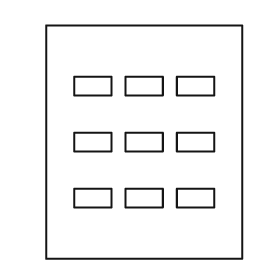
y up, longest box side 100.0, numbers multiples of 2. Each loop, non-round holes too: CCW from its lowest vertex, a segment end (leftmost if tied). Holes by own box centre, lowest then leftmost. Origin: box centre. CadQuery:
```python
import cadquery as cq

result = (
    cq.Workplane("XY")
    .moveTo(-42.0, -50.0)
    .lineTo(42.0, -50.0)
    .lineTo(42.0, 50.0)
    .lineTo(-42.0, 50.0)
    .close()
    .moveTo(-30.0, -28.0)
    .lineTo(-14.0, -28.0)
    .lineTo(-14.0, -20.0)
    .lineTo(-30.0, -20.0)
    .close()
    .moveTo(-8.0, -28.0)
    .lineTo(8.0, -28.0)
    .lineTo(8.0, -20.0)
    .lineTo(-8.0, -20.0)
    .close()
    .moveTo(14.0, -28.0)
    .lineTo(30.0, -28.0)
    .lineTo(30.0, -20.0)
    .lineTo(14.0, -20.0)
    .close()
    .moveTo(-30.0, -4.0)
    .lineTo(-14.0, -4.0)
    .lineTo(-14.0, 4.0)
    .lineTo(-30.0, 4.0)
    .close()
    .moveTo(-8.0, -4.0)
    .lineTo(8.0, -4.0)
    .lineTo(8.0, 4.0)
    .lineTo(-8.0, 4.0)
    .close()
    .moveTo(14.0, -4.0)
    .lineTo(30.0, -4.0)
    .lineTo(30.0, 4.0)
    .lineTo(14.0, 4.0)
    .close()
    .moveTo(-30.0, 20.0)
    .lineTo(-14.0, 20.0)
    .lineTo(-14.0, 28.0)
    .lineTo(-30.0, 28.0)
    .close()
    .moveTo(-8.0, 20.0)
    .lineTo(8.0, 20.0)
    .lineTo(8.0, 28.0)
    .lineTo(-8.0, 28.0)
    .close()
    .moveTo(14.0, 20.0)
    .lineTo(30.0, 20.0)
    .lineTo(30.0, 28.0)
    .lineTo(14.0, 28.0)
    .close()
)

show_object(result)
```